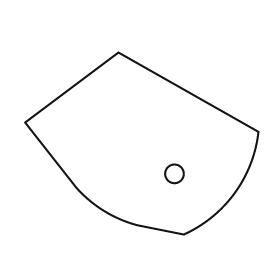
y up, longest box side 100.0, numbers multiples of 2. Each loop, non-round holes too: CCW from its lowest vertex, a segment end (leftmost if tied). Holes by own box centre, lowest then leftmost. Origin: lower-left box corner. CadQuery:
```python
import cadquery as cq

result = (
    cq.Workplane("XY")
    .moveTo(68.0, 0.0)
    .threePointArc((90.0, 18.0), (100.0, 44.0))
    .lineTo(40.0, 78.0)
    .lineTo(0.0, 48.0)
    .lineTo(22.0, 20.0)
    .threePointArc((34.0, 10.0), (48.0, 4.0))
    .close()
    .moveTo(64.0, 26.0)
    .circle(4.0)
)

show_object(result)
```